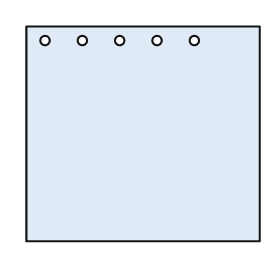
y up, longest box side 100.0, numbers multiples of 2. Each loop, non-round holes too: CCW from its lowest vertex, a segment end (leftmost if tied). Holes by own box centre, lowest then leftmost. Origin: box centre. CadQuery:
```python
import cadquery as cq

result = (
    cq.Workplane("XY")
    .moveTo(-50.0, -46.0)
    .lineTo(50.0, -46.0)
    .lineTo(50.0, 46.0)
    .lineTo(-50.0, 46.0)
    .close()
    .moveTo(-42.0, 40.0)
    .circle(2.0)
    .moveTo(-26.0, 40.0)
    .circle(2.0)
    .moveTo(-10.0, 40.0)
    .circle(2.0)
    .moveTo(6.0, 40.0)
    .circle(2.0)
    .moveTo(22.0, 40.0)
    .circle(2.0)
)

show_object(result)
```